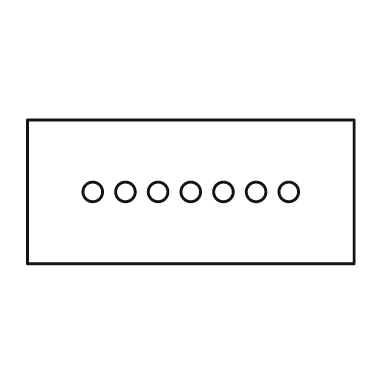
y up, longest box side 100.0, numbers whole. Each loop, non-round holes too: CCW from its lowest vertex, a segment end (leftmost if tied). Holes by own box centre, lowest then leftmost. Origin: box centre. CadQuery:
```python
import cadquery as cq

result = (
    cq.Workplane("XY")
    .moveTo(-50.0, -22.0)
    .lineTo(50.0, -22.0)
    .lineTo(50.0, 22.0)
    .lineTo(-50.0, 22.0)
    .close()
    .moveTo(-30.0, 0.0)
    .circle(3.0)
    .moveTo(-20.0, 0.0)
    .circle(3.0)
    .moveTo(-10.0, 0.0)
    .circle(3.0)
    .moveTo(0.0, 0.0)
    .circle(3.0)
    .moveTo(10.0, 0.0)
    .circle(3.0)
    .moveTo(20.0, 0.0)
    .circle(3.0)
    .moveTo(30.0, 0.0)
    .circle(3.0)
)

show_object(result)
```